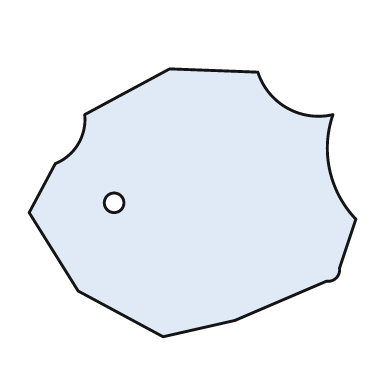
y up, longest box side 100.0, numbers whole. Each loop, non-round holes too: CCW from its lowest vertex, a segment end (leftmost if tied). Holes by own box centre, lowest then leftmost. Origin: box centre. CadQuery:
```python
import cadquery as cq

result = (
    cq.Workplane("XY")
    .moveTo(-9.0, -41.0)
    .lineTo(13.0, -36.0)
    .lineTo(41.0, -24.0)
    .threePointArc((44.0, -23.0), (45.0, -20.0))
    .lineTo(50.0, -5.0)
    .threePointArc((42.0, 10.0), (43.0, 27.0))
    .threePointArc((29.0, 29.0), (20.0, 40.0))
    .lineTo(-7.0, 41.0)
    .lineTo(-33.0, 27.0)
    .threePointArc((-35.0, 18.0), (-42.0, 12.0))
    .lineTo(-50.0, -3.0)
    .lineTo(-35.0, -27.0)
    .close()
    .moveTo(-24.0, 0.0)
    .circle(3.0)
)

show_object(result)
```